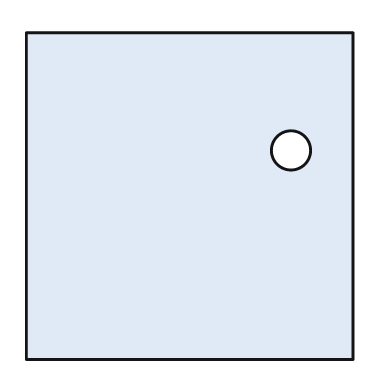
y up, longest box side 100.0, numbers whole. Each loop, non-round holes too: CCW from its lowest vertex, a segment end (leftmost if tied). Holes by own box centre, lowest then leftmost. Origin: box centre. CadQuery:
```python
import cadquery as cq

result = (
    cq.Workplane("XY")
    .moveTo(-50.0, -50.0)
    .lineTo(50.0, -50.0)
    .lineTo(50.0, 50.0)
    .lineTo(-50.0, 50.0)
    .close()
    .moveTo(31.0, 14.0)
    .circle(6.0)
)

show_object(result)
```